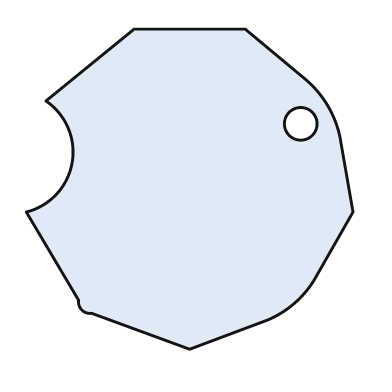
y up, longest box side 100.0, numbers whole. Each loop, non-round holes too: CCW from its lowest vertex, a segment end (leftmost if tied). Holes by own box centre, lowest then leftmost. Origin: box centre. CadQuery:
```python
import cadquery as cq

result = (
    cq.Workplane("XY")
    .moveTo(0.0, -49.0)
    .lineTo(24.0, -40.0)
    .threePointArc((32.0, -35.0), (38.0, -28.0))
    .lineTo(50.0, -7.0)
    .lineTo(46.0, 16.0)
    .threePointArc((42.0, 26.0), (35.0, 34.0))
    .lineTo(17.0, 49.0)
    .lineTo(-17.0, 49.0)
    .lineTo(-44.0, 27.0)
    .threePointArc((-36.0, 8.0), (-50.0, -7.0))
    .lineTo(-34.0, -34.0)
    .threePointArc((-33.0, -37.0), (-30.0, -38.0))
    .close()
    .moveTo(34.0, 20.0)
    .circle(5.0)
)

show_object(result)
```